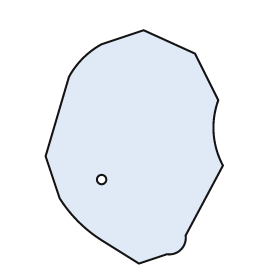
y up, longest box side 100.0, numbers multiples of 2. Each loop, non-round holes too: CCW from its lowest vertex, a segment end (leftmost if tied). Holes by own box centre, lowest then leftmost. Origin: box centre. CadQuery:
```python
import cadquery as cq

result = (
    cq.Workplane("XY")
    .moveTo(2.0, -50.0)
    .lineTo(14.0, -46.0)
    .threePointArc((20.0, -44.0), (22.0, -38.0))
    .lineTo(38.0, -8.0)
    .threePointArc((34.0, 6.0), (36.0, 20.0))
    .lineTo(26.0, 40.0)
    .lineTo(4.0, 50.0)
    .lineTo(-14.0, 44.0)
    .threePointArc((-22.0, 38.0), (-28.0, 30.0))
    .lineTo(-38.0, -4.0)
    .lineTo(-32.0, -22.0)
    .threePointArc((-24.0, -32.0), (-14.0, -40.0))
    .close()
    .moveTo(-14.0, -14.0)
    .circle(2.0)
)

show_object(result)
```